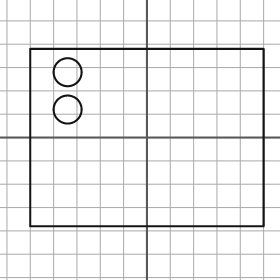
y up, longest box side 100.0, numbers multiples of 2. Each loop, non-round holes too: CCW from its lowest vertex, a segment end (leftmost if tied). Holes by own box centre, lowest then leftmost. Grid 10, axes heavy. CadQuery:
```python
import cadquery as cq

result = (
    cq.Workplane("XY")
    .moveTo(-50.0, -38.0)
    .lineTo(50.0, -38.0)
    .lineTo(50.0, 38.0)
    .lineTo(-50.0, 38.0)
    .close()
    .moveTo(-34.0, 12.0)
    .circle(6.0)
    .moveTo(-34.0, 28.0)
    .circle(6.0)
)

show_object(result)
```